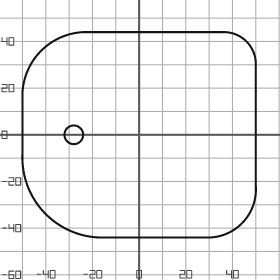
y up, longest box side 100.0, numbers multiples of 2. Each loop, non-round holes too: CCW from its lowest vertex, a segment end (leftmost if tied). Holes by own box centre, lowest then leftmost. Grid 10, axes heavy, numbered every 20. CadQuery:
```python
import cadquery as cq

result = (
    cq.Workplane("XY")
    .moveTo(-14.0, -44.0)
    .lineTo(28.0, -44.0)
    .threePointArc((44.0, -38.0), (50.0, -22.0))
    .lineTo(50.0, 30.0)
    .threePointArc((46.0, 40.0), (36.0, 44.0))
    .lineTo(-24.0, 44.0)
    .threePointArc((-42.0, 36.0), (-50.0, 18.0))
    .lineTo(-50.0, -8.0)
    .threePointArc((-40.0, -34.0), (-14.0, -44.0))
    .close()
    .moveTo(-28.0, 0.0)
    .circle(4.0)
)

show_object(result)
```